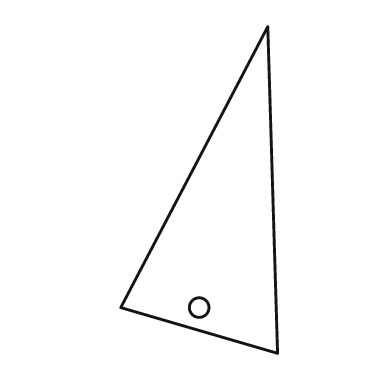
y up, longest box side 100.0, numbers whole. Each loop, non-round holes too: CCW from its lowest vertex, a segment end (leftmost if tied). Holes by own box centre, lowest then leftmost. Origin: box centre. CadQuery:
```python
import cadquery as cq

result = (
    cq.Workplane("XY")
    .moveTo(24.0, -50.0)
    .lineTo(21.0, 50.0)
    .lineTo(-24.0, -36.0)
    .close()
    .moveTo(0.0, -36.0)
    .circle(3.0)
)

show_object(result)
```